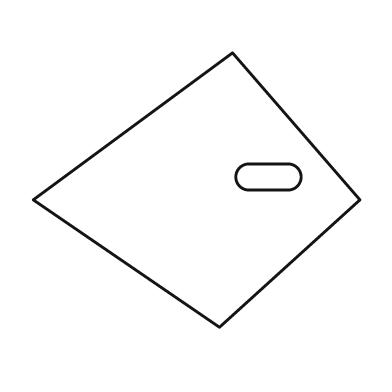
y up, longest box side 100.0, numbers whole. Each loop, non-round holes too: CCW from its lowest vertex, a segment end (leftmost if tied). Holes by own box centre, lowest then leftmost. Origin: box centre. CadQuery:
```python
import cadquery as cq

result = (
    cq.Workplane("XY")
    .moveTo(7.0, -42.0)
    .lineTo(50.0, -3.0)
    .lineTo(11.0, 42.0)
    .lineTo(-50.0, -3.0)
    .close()
    .moveTo(16.0, 0.0)
    .lineTo(28.0, 0.0)
    .threePointArc((32.0, 4.0), (28.0, 8.0))
    .lineTo(16.0, 8.0)
    .threePointArc((12.0, 4.0), (16.0, 0.0))
    .close()
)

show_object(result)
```